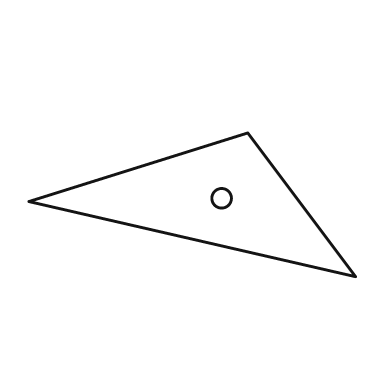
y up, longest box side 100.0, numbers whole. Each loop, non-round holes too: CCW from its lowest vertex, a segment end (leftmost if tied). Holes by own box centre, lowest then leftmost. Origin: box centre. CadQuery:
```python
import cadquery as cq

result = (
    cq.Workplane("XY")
    .moveTo(50.0, -22.0)
    .lineTo(17.0, 22.0)
    .lineTo(-50.0, 1.0)
    .close()
    .moveTo(9.0, 2.0)
    .circle(3.0)
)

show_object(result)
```